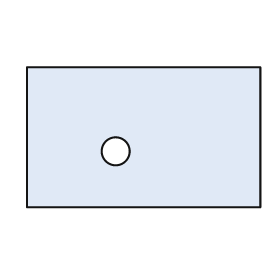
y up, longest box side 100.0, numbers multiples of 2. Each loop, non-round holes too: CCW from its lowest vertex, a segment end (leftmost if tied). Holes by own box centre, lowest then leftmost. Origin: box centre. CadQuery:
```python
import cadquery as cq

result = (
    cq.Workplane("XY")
    .moveTo(-50.0, -30.0)
    .lineTo(50.0, -30.0)
    .lineTo(50.0, 30.0)
    .lineTo(-50.0, 30.0)
    .close()
    .moveTo(-12.0, -6.0)
    .circle(6.0)
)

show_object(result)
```